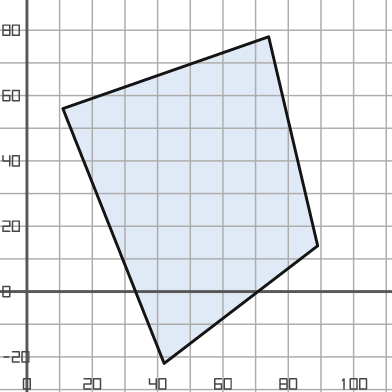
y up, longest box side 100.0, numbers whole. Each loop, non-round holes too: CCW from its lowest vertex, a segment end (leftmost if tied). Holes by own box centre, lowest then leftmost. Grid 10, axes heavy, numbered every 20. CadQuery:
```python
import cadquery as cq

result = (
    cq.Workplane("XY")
    .moveTo(42.0, -22.0)
    .lineTo(89.0, 14.0)
    .lineTo(74.0, 78.0)
    .lineTo(11.0, 56.0)
    .close()
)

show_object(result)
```